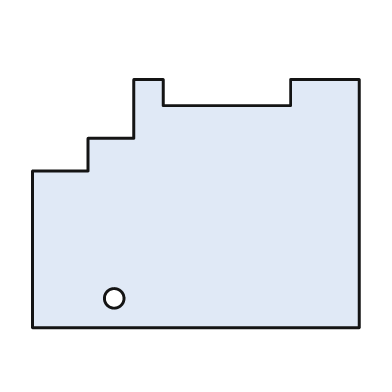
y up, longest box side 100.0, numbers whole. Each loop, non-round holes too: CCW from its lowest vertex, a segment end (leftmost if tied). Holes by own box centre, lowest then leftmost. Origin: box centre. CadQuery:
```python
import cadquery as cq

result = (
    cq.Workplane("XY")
    .moveTo(-50.0, -38.0)
    .lineTo(50.0, -38.0)
    .lineTo(50.0, 38.0)
    .lineTo(29.0, 38.0)
    .lineTo(29.0, 30.0)
    .lineTo(-10.0, 30.0)
    .lineTo(-10.0, 38.0)
    .lineTo(-19.0, 38.0)
    .lineTo(-19.0, 20.0)
    .lineTo(-33.0, 20.0)
    .lineTo(-33.0, 10.0)
    .lineTo(-50.0, 10.0)
    .close()
    .moveTo(-25.0, -29.0)
    .circle(3.0)
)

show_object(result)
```